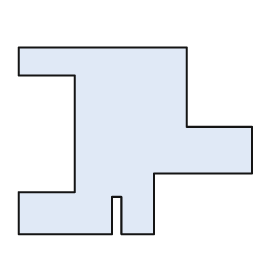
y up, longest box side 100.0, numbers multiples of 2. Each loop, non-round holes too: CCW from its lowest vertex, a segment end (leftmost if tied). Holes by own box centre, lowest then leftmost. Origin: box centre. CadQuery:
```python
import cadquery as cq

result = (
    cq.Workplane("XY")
    .moveTo(-50.0, -40.0)
    .lineTo(-10.0, -40.0)
    .lineTo(-10.0, -24.0)
    .lineTo(-6.0, -24.0)
    .lineTo(-6.0, -40.0)
    .lineTo(8.0, -40.0)
    .lineTo(8.0, -14.0)
    .lineTo(50.0, -14.0)
    .lineTo(50.0, 6.0)
    .lineTo(22.0, 6.0)
    .lineTo(22.0, 40.0)
    .lineTo(-50.0, 40.0)
    .lineTo(-50.0, 28.0)
    .lineTo(-26.0, 28.0)
    .lineTo(-26.0, -22.0)
    .lineTo(-50.0, -22.0)
    .close()
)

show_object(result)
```